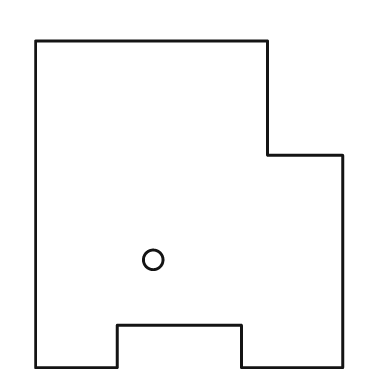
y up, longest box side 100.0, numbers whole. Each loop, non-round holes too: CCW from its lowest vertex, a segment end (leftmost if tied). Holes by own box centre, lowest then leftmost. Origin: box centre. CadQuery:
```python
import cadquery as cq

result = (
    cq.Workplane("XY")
    .moveTo(-47.0, -50.0)
    .lineTo(-22.0, -50.0)
    .lineTo(-22.0, -37.0)
    .lineTo(16.0, -37.0)
    .lineTo(16.0, -50.0)
    .lineTo(47.0, -50.0)
    .lineTo(47.0, 15.0)
    .lineTo(24.0, 15.0)
    .lineTo(24.0, 50.0)
    .lineTo(-47.0, 50.0)
    .close()
    .moveTo(-11.0, -17.0)
    .circle(3.0)
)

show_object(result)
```